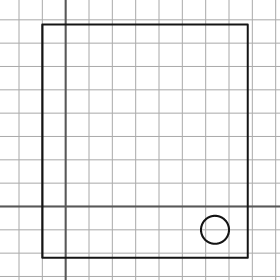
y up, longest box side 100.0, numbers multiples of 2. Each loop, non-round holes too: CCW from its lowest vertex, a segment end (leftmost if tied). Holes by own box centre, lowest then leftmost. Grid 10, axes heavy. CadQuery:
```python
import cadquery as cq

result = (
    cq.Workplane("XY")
    .moveTo(-10.0, -22.0)
    .lineTo(78.0, -22.0)
    .lineTo(78.0, 78.0)
    .lineTo(-10.0, 78.0)
    .close()
    .moveTo(64.0, -10.0)
    .circle(6.0)
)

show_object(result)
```